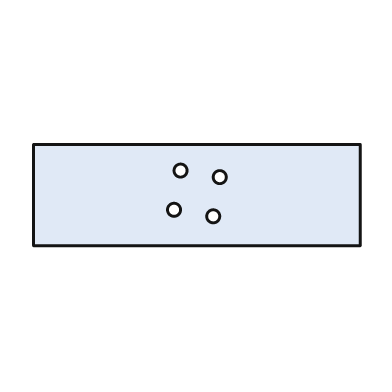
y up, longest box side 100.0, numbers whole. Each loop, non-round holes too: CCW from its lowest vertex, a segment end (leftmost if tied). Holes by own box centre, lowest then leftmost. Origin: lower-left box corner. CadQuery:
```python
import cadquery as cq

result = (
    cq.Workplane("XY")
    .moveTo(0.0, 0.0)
    .lineTo(100.0, 0.0)
    .lineTo(100.0, 31.0)
    .lineTo(0.0, 31.0)
    .close()
    .moveTo(55.0, 9.0)
    .circle(2.0)
    .moveTo(43.0, 11.0)
    .circle(2.0)
    .moveTo(57.0, 21.0)
    .circle(2.0)
    .moveTo(45.0, 23.0)
    .circle(2.0)
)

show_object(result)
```